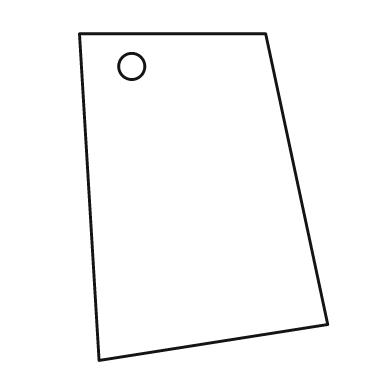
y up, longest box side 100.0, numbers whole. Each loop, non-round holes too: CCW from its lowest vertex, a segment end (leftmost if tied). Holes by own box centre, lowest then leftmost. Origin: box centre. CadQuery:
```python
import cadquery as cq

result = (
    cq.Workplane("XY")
    .moveTo(-32.0, -50.0)
    .lineTo(38.0, -39.0)
    .lineTo(19.0, 50.0)
    .lineTo(-38.0, 50.0)
    .close()
    .moveTo(-22.0, 40.0)
    .circle(4.0)
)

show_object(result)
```